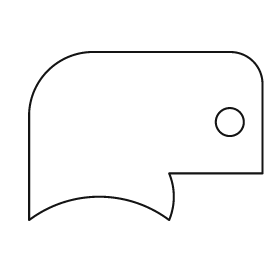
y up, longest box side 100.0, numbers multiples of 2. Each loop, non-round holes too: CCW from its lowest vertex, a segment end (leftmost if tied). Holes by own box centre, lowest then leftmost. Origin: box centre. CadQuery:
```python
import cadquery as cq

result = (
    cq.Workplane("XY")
    .moveTo(-50.0, -36.0)
    .threePointArc((-20.0, -26.0), (10.0, -36.0))
    .threePointArc((12.0, -26.0), (10.0, -16.0))
    .lineTo(50.0, -16.0)
    .lineTo(50.0, 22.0)
    .threePointArc((46.0, 32.0), (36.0, 36.0))
    .lineTo(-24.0, 36.0)
    .threePointArc((-42.0, 28.0), (-50.0, 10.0))
    .close()
    .moveTo(36.0, 6.0)
    .circle(6.0)
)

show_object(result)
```